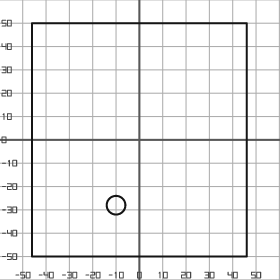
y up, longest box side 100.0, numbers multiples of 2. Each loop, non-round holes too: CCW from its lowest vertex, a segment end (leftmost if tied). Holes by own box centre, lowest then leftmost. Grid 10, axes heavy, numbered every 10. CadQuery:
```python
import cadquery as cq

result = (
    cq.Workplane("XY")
    .moveTo(-46.0, -50.0)
    .lineTo(46.0, -50.0)
    .lineTo(46.0, 50.0)
    .lineTo(-46.0, 50.0)
    .close()
    .moveTo(-10.0, -28.0)
    .circle(4.0)
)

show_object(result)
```